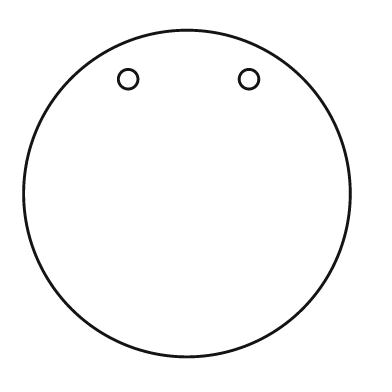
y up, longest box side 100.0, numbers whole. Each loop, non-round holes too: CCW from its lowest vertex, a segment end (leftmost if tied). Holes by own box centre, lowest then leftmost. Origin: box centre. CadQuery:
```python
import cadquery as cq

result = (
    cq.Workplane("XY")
    .moveTo(0.0, 0.0)
    .circle(50.0)
    .moveTo(-18.0, 35.0)
    .circle(3.0)
    .moveTo(19.0, 35.0)
    .circle(3.0)
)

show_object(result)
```